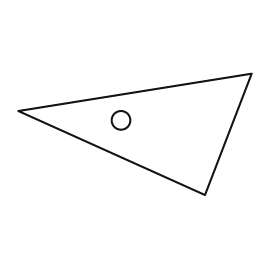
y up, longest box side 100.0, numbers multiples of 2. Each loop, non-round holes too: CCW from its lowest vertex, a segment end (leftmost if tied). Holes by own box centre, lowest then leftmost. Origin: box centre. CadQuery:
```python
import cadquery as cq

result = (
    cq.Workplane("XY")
    .moveTo(30.0, -26.0)
    .lineTo(50.0, 26.0)
    .lineTo(-50.0, 10.0)
    .close()
    .moveTo(-6.0, 6.0)
    .circle(4.0)
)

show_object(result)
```